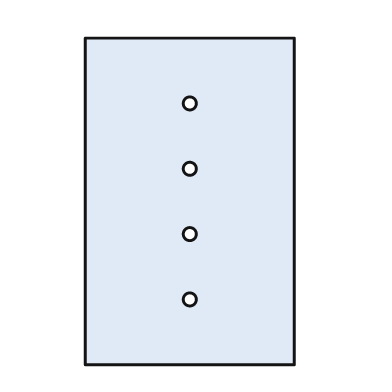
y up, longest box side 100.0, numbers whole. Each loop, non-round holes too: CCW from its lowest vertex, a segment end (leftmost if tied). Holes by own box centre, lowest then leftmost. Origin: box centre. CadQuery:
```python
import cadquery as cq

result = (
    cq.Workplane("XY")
    .moveTo(-32.0, -50.0)
    .lineTo(32.0, -50.0)
    .lineTo(32.0, 50.0)
    .lineTo(-32.0, 50.0)
    .close()
    .moveTo(0.0, -30.0)
    .circle(2.0)
    .moveTo(0.0, -10.0)
    .circle(2.0)
    .moveTo(0.0, 10.0)
    .circle(2.0)
    .moveTo(0.0, 30.0)
    .circle(2.0)
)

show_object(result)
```